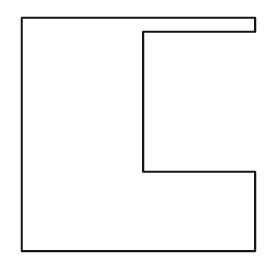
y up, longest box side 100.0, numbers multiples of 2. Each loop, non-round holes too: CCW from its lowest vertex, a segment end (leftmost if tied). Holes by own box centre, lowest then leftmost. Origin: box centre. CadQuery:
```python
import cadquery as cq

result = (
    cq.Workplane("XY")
    .moveTo(-50.0, -50.0)
    .lineTo(50.0, -50.0)
    .lineTo(50.0, -16.0)
    .lineTo(2.0, -16.0)
    .lineTo(2.0, 44.0)
    .lineTo(50.0, 44.0)
    .lineTo(50.0, 50.0)
    .lineTo(-50.0, 50.0)
    .close()
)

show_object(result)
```